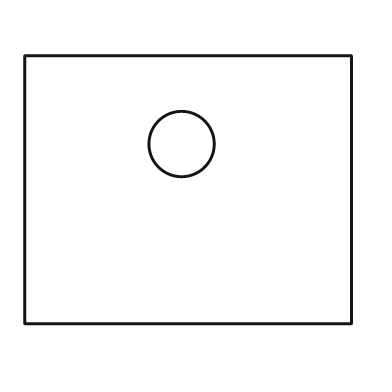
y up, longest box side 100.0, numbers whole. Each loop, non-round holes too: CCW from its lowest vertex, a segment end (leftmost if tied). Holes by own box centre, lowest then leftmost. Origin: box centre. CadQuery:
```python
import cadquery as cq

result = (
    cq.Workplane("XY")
    .moveTo(-50.0, -41.0)
    .lineTo(50.0, -41.0)
    .lineTo(50.0, 41.0)
    .lineTo(-50.0, 41.0)
    .close()
    .moveTo(-2.0, 14.0)
    .circle(10.0)
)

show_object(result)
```